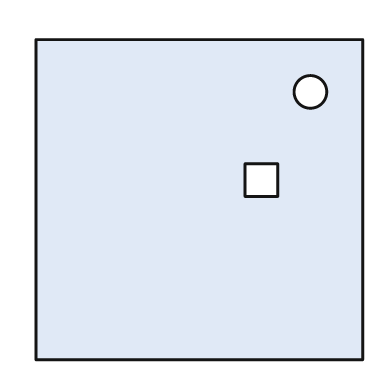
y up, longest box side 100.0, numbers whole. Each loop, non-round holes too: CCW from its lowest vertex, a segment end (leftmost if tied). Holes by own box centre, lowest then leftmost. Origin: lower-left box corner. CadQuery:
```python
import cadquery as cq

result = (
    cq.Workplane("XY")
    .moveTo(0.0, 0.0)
    .lineTo(100.0, 0.0)
    .lineTo(100.0, 98.0)
    .lineTo(0.0, 98.0)
    .close()
    .moveTo(64.0, 50.0)
    .lineTo(74.0, 50.0)
    .lineTo(74.0, 60.0)
    .lineTo(64.0, 60.0)
    .close()
    .moveTo(84.0, 82.0)
    .circle(5.0)
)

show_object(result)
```